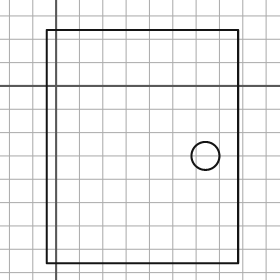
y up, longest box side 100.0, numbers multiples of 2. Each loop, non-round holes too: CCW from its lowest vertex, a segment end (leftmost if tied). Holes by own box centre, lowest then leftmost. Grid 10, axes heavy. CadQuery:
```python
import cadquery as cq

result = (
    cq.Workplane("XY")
    .moveTo(-4.0, -76.0)
    .lineTo(78.0, -76.0)
    .lineTo(78.0, 24.0)
    .lineTo(-4.0, 24.0)
    .close()
    .moveTo(64.0, -30.0)
    .circle(6.0)
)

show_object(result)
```